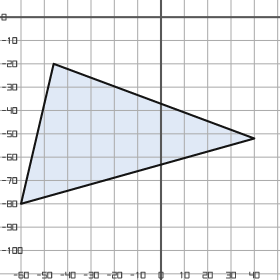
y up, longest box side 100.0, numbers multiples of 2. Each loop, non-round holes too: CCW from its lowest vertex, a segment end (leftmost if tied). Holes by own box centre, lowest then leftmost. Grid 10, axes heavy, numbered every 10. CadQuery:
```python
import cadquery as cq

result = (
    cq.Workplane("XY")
    .moveTo(-60.0, -80.0)
    .lineTo(40.0, -52.0)
    .lineTo(-46.0, -20.0)
    .close()
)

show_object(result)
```